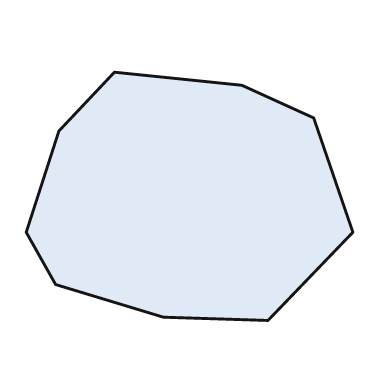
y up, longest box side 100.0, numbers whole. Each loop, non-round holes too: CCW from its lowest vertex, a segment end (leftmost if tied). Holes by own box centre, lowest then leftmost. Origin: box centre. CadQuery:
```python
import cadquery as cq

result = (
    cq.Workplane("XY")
    .moveTo(24.0, -38.0)
    .lineTo(50.0, -11.0)
    .lineTo(38.0, 24.0)
    .lineTo(16.0, 34.0)
    .lineTo(-23.0, 38.0)
    .lineTo(-40.0, 20.0)
    .lineTo(-50.0, -11.0)
    .lineTo(-41.0, -27.0)
    .lineTo(-8.0, -37.0)
    .close()
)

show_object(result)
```